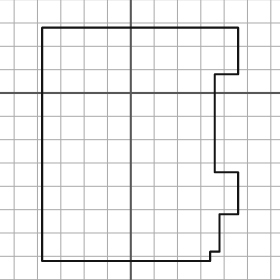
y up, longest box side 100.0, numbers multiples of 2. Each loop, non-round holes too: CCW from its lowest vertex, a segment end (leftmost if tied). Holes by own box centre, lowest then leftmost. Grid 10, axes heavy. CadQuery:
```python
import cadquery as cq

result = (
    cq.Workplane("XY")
    .moveTo(-38.0, -72.0)
    .lineTo(34.0, -72.0)
    .lineTo(34.0, -68.0)
    .lineTo(38.0, -68.0)
    .lineTo(38.0, -52.0)
    .lineTo(46.0, -52.0)
    .lineTo(46.0, -34.0)
    .lineTo(36.0, -34.0)
    .lineTo(36.0, 8.0)
    .lineTo(46.0, 8.0)
    .lineTo(46.0, 28.0)
    .lineTo(-38.0, 28.0)
    .close()
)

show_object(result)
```